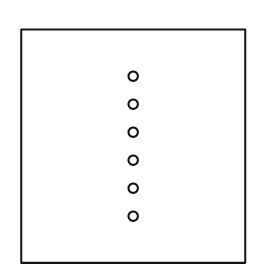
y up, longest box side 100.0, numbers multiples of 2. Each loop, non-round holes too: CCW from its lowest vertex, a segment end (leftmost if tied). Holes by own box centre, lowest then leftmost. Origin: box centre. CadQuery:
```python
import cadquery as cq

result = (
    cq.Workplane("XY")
    .moveTo(-48.0, -50.0)
    .lineTo(48.0, -50.0)
    .lineTo(48.0, 50.0)
    .lineTo(-48.0, 50.0)
    .close()
    .moveTo(0.0, -30.0)
    .circle(2.0)
    .moveTo(0.0, -18.0)
    .circle(2.0)
    .moveTo(0.0, -6.0)
    .circle(2.0)
    .moveTo(0.0, 6.0)
    .circle(2.0)
    .moveTo(0.0, 18.0)
    .circle(2.0)
    .moveTo(0.0, 30.0)
    .circle(2.0)
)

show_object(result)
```